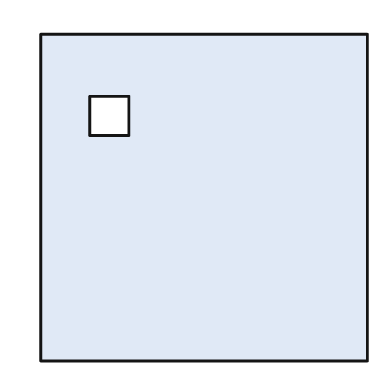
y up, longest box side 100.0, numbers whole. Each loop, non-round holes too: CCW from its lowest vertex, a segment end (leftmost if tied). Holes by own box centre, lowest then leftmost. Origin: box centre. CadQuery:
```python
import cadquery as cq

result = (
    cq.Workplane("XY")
    .moveTo(-50.0, -50.0)
    .lineTo(50.0, -50.0)
    .lineTo(50.0, 50.0)
    .lineTo(-50.0, 50.0)
    .close()
    .moveTo(-35.0, 19.0)
    .lineTo(-23.0, 19.0)
    .lineTo(-23.0, 31.0)
    .lineTo(-35.0, 31.0)
    .close()
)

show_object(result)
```